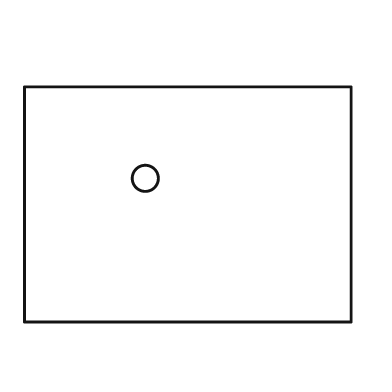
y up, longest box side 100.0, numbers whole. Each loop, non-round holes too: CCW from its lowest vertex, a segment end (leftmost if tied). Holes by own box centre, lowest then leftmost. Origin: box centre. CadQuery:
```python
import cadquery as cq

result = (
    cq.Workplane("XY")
    .moveTo(-50.0, -36.0)
    .lineTo(50.0, -36.0)
    .lineTo(50.0, 36.0)
    .lineTo(-50.0, 36.0)
    .close()
    .moveTo(-13.0, 8.0)
    .circle(4.0)
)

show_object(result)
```